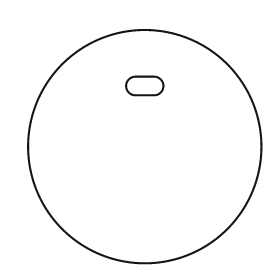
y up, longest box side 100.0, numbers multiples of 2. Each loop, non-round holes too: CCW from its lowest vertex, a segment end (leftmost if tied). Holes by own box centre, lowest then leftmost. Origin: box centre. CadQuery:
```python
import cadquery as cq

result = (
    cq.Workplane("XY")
    .moveTo(0.0, 0.0)
    .circle(50.0)
    .moveTo(-4.0, 22.0)
    .lineTo(4.0, 22.0)
    .threePointArc((8.0, 26.0), (4.0, 30.0))
    .lineTo(-4.0, 30.0)
    .threePointArc((-8.0, 26.0), (-4.0, 22.0))
    .close()
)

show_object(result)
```